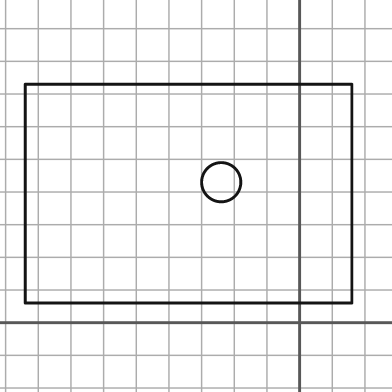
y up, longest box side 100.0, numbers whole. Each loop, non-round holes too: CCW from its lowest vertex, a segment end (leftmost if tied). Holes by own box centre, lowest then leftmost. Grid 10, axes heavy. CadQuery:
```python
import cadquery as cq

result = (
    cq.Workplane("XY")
    .moveTo(-84.0, 6.0)
    .lineTo(16.0, 6.0)
    .lineTo(16.0, 73.0)
    .lineTo(-84.0, 73.0)
    .close()
    .moveTo(-24.0, 43.0)
    .circle(6.0)
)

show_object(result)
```